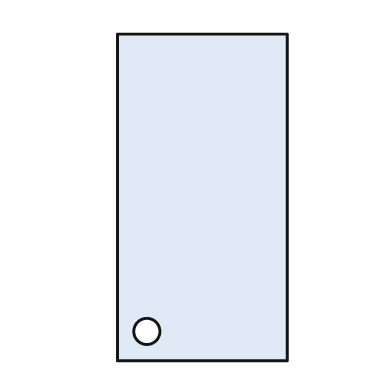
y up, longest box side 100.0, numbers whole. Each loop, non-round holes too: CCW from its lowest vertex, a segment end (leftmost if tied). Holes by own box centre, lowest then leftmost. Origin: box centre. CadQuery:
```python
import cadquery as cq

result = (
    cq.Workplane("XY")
    .moveTo(-26.0, -50.0)
    .lineTo(26.0, -50.0)
    .lineTo(26.0, 50.0)
    .lineTo(-26.0, 50.0)
    .close()
    .moveTo(-17.0, -41.0)
    .circle(4.0)
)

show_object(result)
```